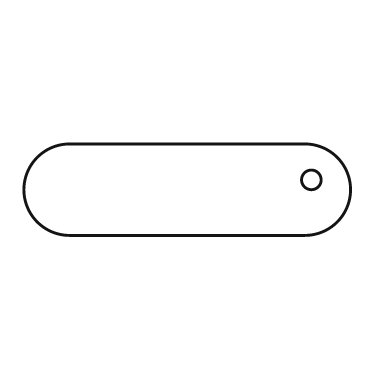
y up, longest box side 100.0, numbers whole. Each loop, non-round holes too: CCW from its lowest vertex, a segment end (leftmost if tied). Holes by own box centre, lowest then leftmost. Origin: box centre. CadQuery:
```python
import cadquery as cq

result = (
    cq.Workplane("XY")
    .moveTo(-36.0, -14.0)
    .lineTo(36.0, -14.0)
    .threePointArc((50.0, 0.0), (36.0, 14.0))
    .lineTo(-36.0, 14.0)
    .threePointArc((-50.0, 0.0), (-36.0, -14.0))
    .close()
    .moveTo(38.0, 3.0)
    .circle(3.0)
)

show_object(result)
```